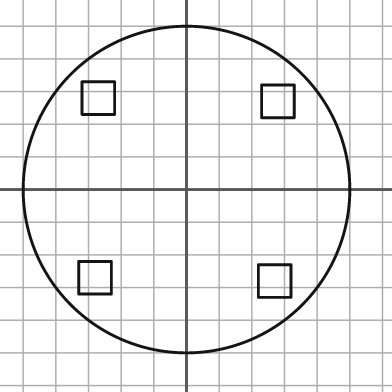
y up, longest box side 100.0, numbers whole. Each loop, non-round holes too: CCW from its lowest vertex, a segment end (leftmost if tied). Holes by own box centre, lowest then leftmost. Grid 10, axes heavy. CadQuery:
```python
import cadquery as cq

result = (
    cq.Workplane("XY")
    .moveTo(0.0, 0.0)
    .circle(50.0)
    .moveTo(22.0, -33.0)
    .lineTo(32.0, -33.0)
    .lineTo(32.0, -23.0)
    .lineTo(22.0, -23.0)
    .close()
    .moveTo(-33.0, -32.0)
    .lineTo(-23.0, -32.0)
    .lineTo(-23.0, -22.0)
    .lineTo(-33.0, -22.0)
    .close()
    .moveTo(23.0, 22.0)
    .lineTo(33.0, 22.0)
    .lineTo(33.0, 32.0)
    .lineTo(23.0, 32.0)
    .close()
    .moveTo(-32.0, 23.0)
    .lineTo(-22.0, 23.0)
    .lineTo(-22.0, 33.0)
    .lineTo(-32.0, 33.0)
    .close()
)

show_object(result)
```